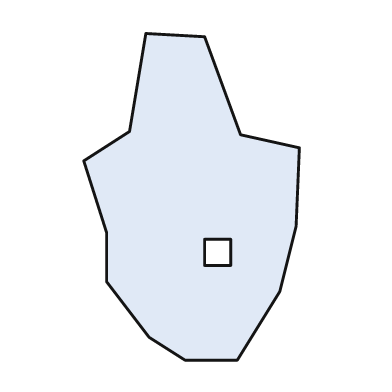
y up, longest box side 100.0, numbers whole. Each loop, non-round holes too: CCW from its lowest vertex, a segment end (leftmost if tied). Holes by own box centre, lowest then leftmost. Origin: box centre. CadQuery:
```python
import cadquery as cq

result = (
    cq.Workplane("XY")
    .moveTo(-2.0, -50.0)
    .lineTo(14.0, -50.0)
    .lineTo(27.0, -29.0)
    .lineTo(32.0, -9.0)
    .lineTo(33.0, 15.0)
    .lineTo(15.0, 19.0)
    .lineTo(4.0, 49.0)
    .lineTo(-14.0, 50.0)
    .lineTo(-19.0, 20.0)
    .lineTo(-33.0, 11.0)
    .lineTo(-26.0, -11.0)
    .lineTo(-26.0, -26.0)
    .lineTo(-13.0, -43.0)
    .close()
    .moveTo(4.0, -21.0)
    .lineTo(12.0, -21.0)
    .lineTo(12.0, -13.0)
    .lineTo(4.0, -13.0)
    .close()
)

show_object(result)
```